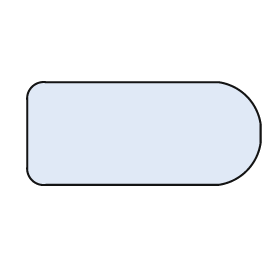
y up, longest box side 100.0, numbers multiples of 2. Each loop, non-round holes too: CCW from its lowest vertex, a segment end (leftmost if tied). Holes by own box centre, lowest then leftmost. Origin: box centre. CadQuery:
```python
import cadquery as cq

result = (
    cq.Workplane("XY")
    .moveTo(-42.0, -22.0)
    .lineTo(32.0, -22.0)
    .threePointArc((44.0, -16.0), (50.0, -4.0))
    .lineTo(50.0, 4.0)
    .threePointArc((44.0, 16.0), (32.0, 22.0))
    .lineTo(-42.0, 22.0)
    .threePointArc((-48.0, 20.0), (-50.0, 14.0))
    .lineTo(-50.0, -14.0)
    .threePointArc((-48.0, -20.0), (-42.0, -22.0))
    .close()
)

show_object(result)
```